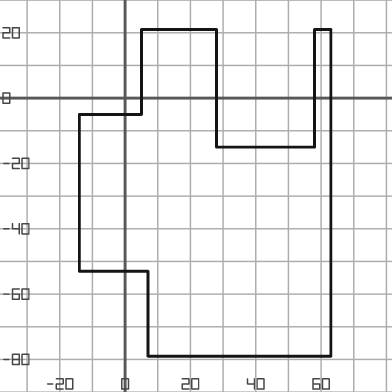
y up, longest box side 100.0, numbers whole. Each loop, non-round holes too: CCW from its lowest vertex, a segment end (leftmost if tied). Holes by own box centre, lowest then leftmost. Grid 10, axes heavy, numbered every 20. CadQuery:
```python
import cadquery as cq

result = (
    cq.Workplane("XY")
    .moveTo(7.0, -79.0)
    .lineTo(63.0, -79.0)
    .lineTo(63.0, 21.0)
    .lineTo(58.0, 21.0)
    .lineTo(58.0, -15.0)
    .lineTo(28.0, -15.0)
    .lineTo(28.0, 21.0)
    .lineTo(5.0, 21.0)
    .lineTo(5.0, -5.0)
    .lineTo(-14.0, -5.0)
    .lineTo(-14.0, -53.0)
    .lineTo(7.0, -53.0)
    .close()
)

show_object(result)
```